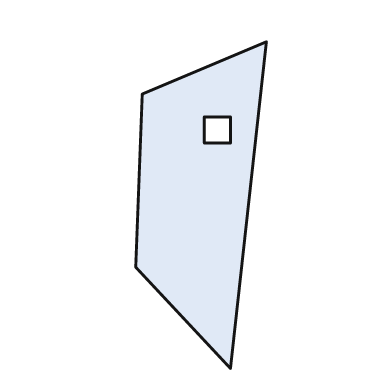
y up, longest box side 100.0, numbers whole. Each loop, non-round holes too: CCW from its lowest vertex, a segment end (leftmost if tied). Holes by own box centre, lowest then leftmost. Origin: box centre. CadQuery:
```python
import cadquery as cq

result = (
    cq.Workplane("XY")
    .moveTo(9.0, -50.0)
    .lineTo(20.0, 50.0)
    .lineTo(-18.0, 34.0)
    .lineTo(-20.0, -19.0)
    .close()
    .moveTo(1.0, 19.0)
    .lineTo(9.0, 19.0)
    .lineTo(9.0, 27.0)
    .lineTo(1.0, 27.0)
    .close()
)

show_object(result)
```